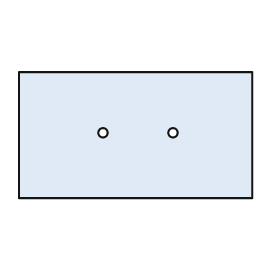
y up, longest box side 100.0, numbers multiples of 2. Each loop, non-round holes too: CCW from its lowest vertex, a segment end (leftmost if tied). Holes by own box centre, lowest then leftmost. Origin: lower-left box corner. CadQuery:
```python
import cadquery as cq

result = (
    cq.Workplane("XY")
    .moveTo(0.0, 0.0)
    .lineTo(100.0, 0.0)
    .lineTo(100.0, 54.0)
    .lineTo(0.0, 54.0)
    .close()
    .moveTo(36.0, 28.0)
    .circle(2.0)
    .moveTo(66.0, 28.0)
    .circle(2.0)
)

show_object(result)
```